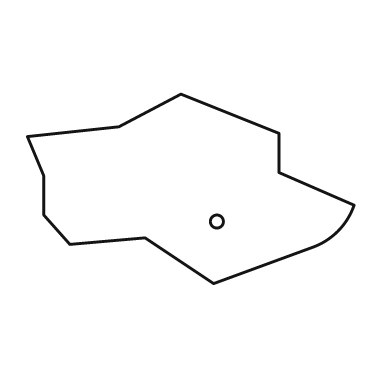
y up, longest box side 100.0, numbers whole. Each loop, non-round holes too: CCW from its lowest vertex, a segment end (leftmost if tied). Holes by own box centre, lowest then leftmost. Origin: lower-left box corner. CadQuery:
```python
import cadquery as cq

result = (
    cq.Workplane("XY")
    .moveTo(57.0, 0.0)
    .lineTo(87.0, 11.0)
    .threePointArc((95.0, 16.0), (100.0, 24.0))
    .lineTo(77.0, 34.0)
    .lineTo(77.0, 46.0)
    .lineTo(47.0, 58.0)
    .lineTo(28.0, 48.0)
    .lineTo(0.0, 45.0)
    .lineTo(5.0, 33.0)
    .lineTo(5.0, 21.0)
    .lineTo(13.0, 12.0)
    .lineTo(36.0, 14.0)
    .close()
    .moveTo(58.0, 19.0)
    .circle(2.0)
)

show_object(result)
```